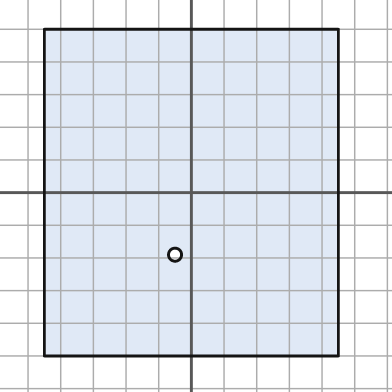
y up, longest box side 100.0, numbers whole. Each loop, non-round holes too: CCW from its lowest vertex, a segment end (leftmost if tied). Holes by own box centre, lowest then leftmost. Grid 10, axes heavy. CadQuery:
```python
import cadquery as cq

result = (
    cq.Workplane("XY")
    .moveTo(-45.0, -50.0)
    .lineTo(45.0, -50.0)
    .lineTo(45.0, 50.0)
    .lineTo(-45.0, 50.0)
    .close()
    .moveTo(-5.0, -19.0)
    .circle(2.0)
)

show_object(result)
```